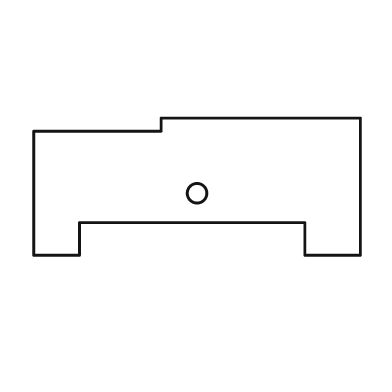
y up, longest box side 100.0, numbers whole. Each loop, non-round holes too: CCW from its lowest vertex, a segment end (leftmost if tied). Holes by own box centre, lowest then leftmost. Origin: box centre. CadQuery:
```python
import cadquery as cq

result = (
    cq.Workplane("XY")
    .moveTo(-50.0, -21.0)
    .lineTo(-36.0, -21.0)
    .lineTo(-36.0, -11.0)
    .lineTo(33.0, -11.0)
    .lineTo(33.0, -21.0)
    .lineTo(50.0, -21.0)
    .lineTo(50.0, 21.0)
    .lineTo(-11.0, 21.0)
    .lineTo(-11.0, 17.0)
    .lineTo(-50.0, 17.0)
    .close()
    .moveTo(0.0, -2.0)
    .circle(3.0)
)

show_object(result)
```